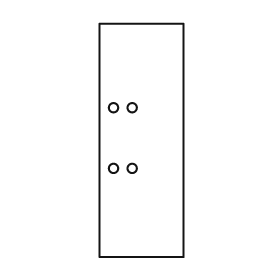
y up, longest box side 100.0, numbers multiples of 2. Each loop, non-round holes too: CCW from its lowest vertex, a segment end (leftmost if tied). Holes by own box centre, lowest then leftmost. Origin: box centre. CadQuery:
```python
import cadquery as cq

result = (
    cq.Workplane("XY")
    .moveTo(-18.0, -50.0)
    .lineTo(18.0, -50.0)
    .lineTo(18.0, 50.0)
    .lineTo(-18.0, 50.0)
    .close()
    .moveTo(-12.0, -12.0)
    .circle(2.0)
    .moveTo(-4.0, -12.0)
    .circle(2.0)
    .moveTo(-12.0, 14.0)
    .circle(2.0)
    .moveTo(-4.0, 14.0)
    .circle(2.0)
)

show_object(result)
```